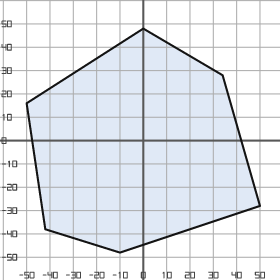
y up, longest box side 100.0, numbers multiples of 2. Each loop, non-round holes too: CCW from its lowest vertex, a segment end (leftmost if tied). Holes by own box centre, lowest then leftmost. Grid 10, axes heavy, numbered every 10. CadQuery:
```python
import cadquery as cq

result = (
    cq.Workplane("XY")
    .moveTo(-10.0, -48.0)
    .lineTo(50.0, -28.0)
    .lineTo(34.0, 28.0)
    .lineTo(0.0, 48.0)
    .lineTo(-50.0, 16.0)
    .lineTo(-42.0, -38.0)
    .close()
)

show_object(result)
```